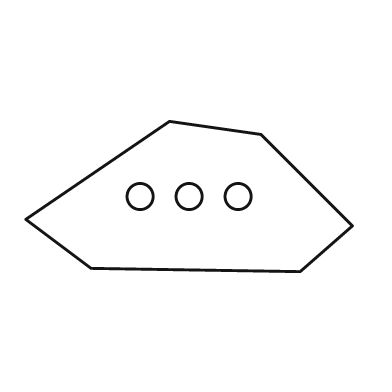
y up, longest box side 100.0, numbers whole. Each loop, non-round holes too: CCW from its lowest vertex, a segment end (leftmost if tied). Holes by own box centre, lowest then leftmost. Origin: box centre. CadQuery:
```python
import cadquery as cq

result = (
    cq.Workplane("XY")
    .moveTo(34.0, -23.0)
    .lineTo(50.0, -9.0)
    .lineTo(22.0, 19.0)
    .lineTo(-6.0, 23.0)
    .lineTo(-50.0, -7.0)
    .lineTo(-30.0, -22.0)
    .close()
    .moveTo(-15.0, 0.0)
    .circle(4.0)
    .moveTo(0.0, 0.0)
    .circle(4.0)
    .moveTo(15.0, 0.0)
    .circle(4.0)
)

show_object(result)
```